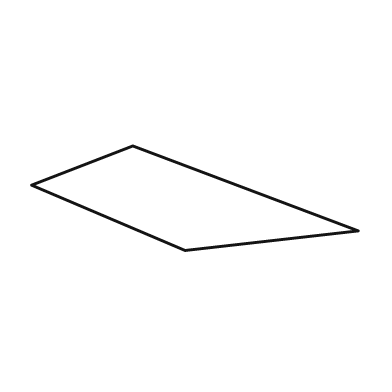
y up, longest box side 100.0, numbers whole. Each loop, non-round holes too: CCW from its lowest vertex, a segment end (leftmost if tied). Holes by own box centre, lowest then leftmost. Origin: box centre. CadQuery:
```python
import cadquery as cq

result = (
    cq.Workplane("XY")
    .moveTo(-3.0, -16.0)
    .lineTo(50.0, -10.0)
    .lineTo(-19.0, 16.0)
    .lineTo(-50.0, 4.0)
    .close()
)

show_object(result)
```